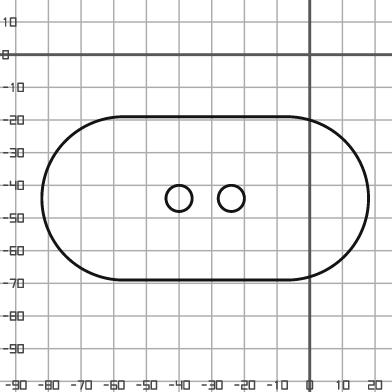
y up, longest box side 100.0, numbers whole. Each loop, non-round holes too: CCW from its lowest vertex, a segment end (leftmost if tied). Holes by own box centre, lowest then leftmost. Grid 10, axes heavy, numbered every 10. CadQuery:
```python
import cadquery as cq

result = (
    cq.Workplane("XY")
    .moveTo(-57.0, -69.0)
    .lineTo(-7.0, -69.0)
    .threePointArc((18.0, -44.0), (-7.0, -19.0))
    .lineTo(-57.0, -19.0)
    .threePointArc((-82.0, -44.0), (-57.0, -69.0))
    .close()
    .moveTo(-40.0, -44.0)
    .circle(4.0)
    .moveTo(-24.0, -44.0)
    .circle(4.0)
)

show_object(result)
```